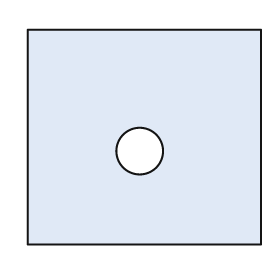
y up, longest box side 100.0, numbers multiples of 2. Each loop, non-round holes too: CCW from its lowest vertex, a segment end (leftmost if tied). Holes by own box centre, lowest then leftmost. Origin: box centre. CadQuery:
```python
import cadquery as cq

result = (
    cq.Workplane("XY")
    .moveTo(-50.0, -46.0)
    .lineTo(50.0, -46.0)
    .lineTo(50.0, 46.0)
    .lineTo(-50.0, 46.0)
    .close()
    .moveTo(-2.0, -6.0)
    .circle(10.0)
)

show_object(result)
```